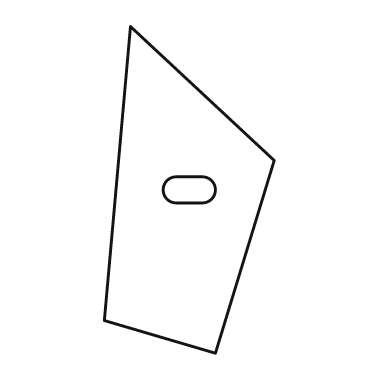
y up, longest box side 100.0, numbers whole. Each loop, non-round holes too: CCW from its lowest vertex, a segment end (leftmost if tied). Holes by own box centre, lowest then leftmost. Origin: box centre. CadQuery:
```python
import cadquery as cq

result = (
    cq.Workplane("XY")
    .moveTo(8.0, -50.0)
    .lineTo(26.0, 9.0)
    .lineTo(-18.0, 50.0)
    .lineTo(-26.0, -40.0)
    .close()
    .moveTo(-4.0, -4.0)
    .lineTo(4.0, -4.0)
    .threePointArc((8.0, 0.0), (4.0, 4.0))
    .lineTo(-4.0, 4.0)
    .threePointArc((-8.0, 0.0), (-4.0, -4.0))
    .close()
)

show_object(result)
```